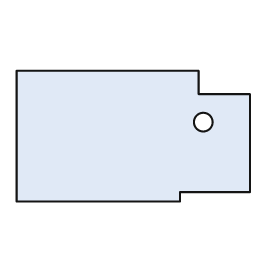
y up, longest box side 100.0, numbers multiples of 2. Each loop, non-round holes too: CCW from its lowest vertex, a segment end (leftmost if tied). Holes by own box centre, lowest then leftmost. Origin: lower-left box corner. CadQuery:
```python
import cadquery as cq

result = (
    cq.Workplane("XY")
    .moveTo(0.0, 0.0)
    .lineTo(70.0, 0.0)
    .lineTo(70.0, 4.0)
    .lineTo(100.0, 4.0)
    .lineTo(100.0, 46.0)
    .lineTo(78.0, 46.0)
    .lineTo(78.0, 56.0)
    .lineTo(0.0, 56.0)
    .close()
    .moveTo(80.0, 34.0)
    .circle(4.0)
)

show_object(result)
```